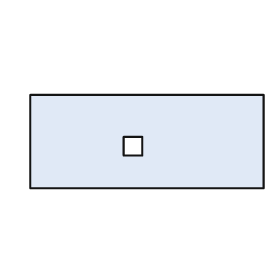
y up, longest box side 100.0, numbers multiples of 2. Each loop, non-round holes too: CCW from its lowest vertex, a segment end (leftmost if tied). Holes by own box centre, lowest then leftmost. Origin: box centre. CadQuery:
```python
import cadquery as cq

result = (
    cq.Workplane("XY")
    .moveTo(-50.0, -20.0)
    .lineTo(50.0, -20.0)
    .lineTo(50.0, 20.0)
    .lineTo(-50.0, 20.0)
    .close()
    .moveTo(-10.0, -6.0)
    .lineTo(-2.0, -6.0)
    .lineTo(-2.0, 2.0)
    .lineTo(-10.0, 2.0)
    .close()
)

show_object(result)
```